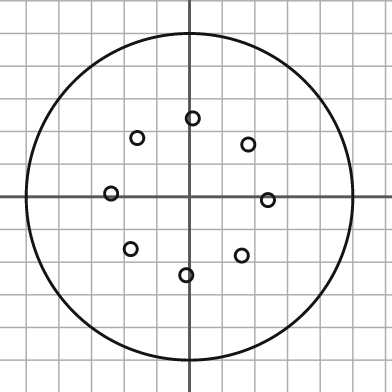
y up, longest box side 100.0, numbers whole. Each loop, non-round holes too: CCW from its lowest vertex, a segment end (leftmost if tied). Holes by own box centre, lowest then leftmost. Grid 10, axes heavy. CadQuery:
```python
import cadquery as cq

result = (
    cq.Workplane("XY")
    .moveTo(0.0, 0.0)
    .circle(50.0)
    .moveTo(-1.0, -24.0)
    .circle(2.0)
    .moveTo(16.0, -18.0)
    .circle(2.0)
    .moveTo(-18.0, -16.0)
    .circle(2.0)
    .moveTo(24.0, -1.0)
    .circle(2.0)
    .moveTo(-24.0, 1.0)
    .circle(2.0)
    .moveTo(18.0, 16.0)
    .circle(2.0)
    .moveTo(-16.0, 18.0)
    .circle(2.0)
    .moveTo(1.0, 24.0)
    .circle(2.0)
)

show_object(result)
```